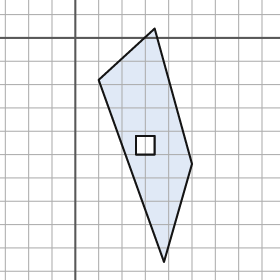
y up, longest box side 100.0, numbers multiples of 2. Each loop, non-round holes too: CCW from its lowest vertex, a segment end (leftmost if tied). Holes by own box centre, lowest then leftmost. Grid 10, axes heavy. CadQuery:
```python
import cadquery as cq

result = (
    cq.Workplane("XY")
    .moveTo(38.0, -96.0)
    .lineTo(50.0, -54.0)
    .lineTo(34.0, 4.0)
    .lineTo(10.0, -18.0)
    .close()
    .moveTo(26.0, -50.0)
    .lineTo(34.0, -50.0)
    .lineTo(34.0, -42.0)
    .lineTo(26.0, -42.0)
    .close()
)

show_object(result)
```